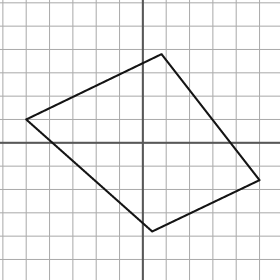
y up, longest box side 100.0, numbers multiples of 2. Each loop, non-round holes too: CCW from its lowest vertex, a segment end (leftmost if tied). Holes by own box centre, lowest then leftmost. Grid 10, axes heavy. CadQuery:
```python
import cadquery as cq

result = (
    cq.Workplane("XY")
    .moveTo(4.0, -38.0)
    .lineTo(50.0, -16.0)
    .lineTo(8.0, 38.0)
    .lineTo(-50.0, 10.0)
    .close()
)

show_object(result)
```